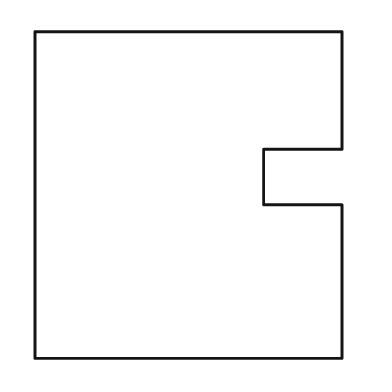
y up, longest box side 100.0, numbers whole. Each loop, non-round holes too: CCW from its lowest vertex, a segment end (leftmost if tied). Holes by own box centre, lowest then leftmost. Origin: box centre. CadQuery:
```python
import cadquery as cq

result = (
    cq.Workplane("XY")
    .moveTo(-47.0, -50.0)
    .lineTo(47.0, -50.0)
    .lineTo(47.0, -3.0)
    .lineTo(23.0, -3.0)
    .lineTo(23.0, 14.0)
    .lineTo(47.0, 14.0)
    .lineTo(47.0, 50.0)
    .lineTo(-47.0, 50.0)
    .close()
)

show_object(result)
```